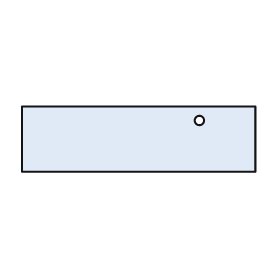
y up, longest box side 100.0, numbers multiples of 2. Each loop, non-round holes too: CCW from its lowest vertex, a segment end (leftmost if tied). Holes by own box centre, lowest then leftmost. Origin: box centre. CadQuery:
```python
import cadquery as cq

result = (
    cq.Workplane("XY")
    .moveTo(-50.0, -14.0)
    .lineTo(50.0, -14.0)
    .lineTo(50.0, 14.0)
    .lineTo(-50.0, 14.0)
    .close()
    .moveTo(26.0, 8.0)
    .circle(2.0)
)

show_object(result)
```